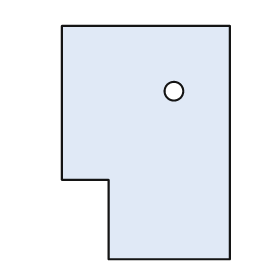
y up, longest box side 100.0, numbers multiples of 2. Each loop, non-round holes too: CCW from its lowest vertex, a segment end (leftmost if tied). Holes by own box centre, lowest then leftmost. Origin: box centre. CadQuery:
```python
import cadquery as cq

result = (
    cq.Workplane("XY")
    .moveTo(-16.0, -50.0)
    .lineTo(36.0, -50.0)
    .lineTo(36.0, 50.0)
    .lineTo(-36.0, 50.0)
    .lineTo(-36.0, -16.0)
    .lineTo(-16.0, -16.0)
    .close()
    .moveTo(12.0, 22.0)
    .circle(4.0)
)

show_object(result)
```